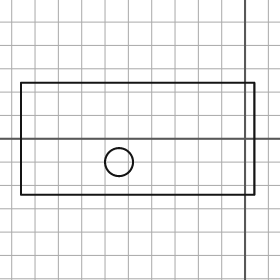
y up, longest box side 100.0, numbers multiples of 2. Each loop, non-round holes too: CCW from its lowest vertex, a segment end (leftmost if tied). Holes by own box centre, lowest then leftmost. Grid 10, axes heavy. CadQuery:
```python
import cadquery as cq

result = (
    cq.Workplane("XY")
    .moveTo(-96.0, -24.0)
    .lineTo(4.0, -24.0)
    .lineTo(4.0, 24.0)
    .lineTo(-96.0, 24.0)
    .close()
    .moveTo(-54.0, -10.0)
    .circle(6.0)
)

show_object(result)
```